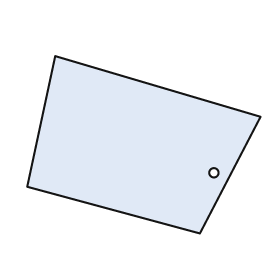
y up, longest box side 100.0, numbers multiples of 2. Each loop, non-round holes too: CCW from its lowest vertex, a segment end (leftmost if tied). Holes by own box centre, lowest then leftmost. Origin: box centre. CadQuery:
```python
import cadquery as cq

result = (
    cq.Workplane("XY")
    .moveTo(24.0, -38.0)
    .lineTo(50.0, 12.0)
    .lineTo(-38.0, 38.0)
    .lineTo(-50.0, -18.0)
    .close()
    .moveTo(30.0, -12.0)
    .circle(2.0)
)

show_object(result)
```